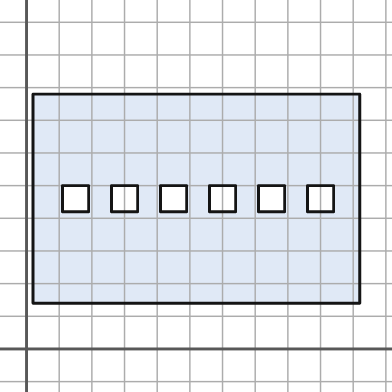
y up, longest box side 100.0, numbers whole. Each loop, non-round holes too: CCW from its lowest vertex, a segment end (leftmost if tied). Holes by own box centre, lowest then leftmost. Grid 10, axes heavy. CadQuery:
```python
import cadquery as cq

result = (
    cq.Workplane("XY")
    .moveTo(2.0, 14.0)
    .lineTo(102.0, 14.0)
    .lineTo(102.0, 78.0)
    .lineTo(2.0, 78.0)
    .close()
    .moveTo(11.0, 42.0)
    .lineTo(19.0, 42.0)
    .lineTo(19.0, 50.0)
    .lineTo(11.0, 50.0)
    .close()
    .moveTo(26.0, 42.0)
    .lineTo(34.0, 42.0)
    .lineTo(34.0, 50.0)
    .lineTo(26.0, 50.0)
    .close()
    .moveTo(41.0, 42.0)
    .lineTo(49.0, 42.0)
    .lineTo(49.0, 50.0)
    .lineTo(41.0, 50.0)
    .close()
    .moveTo(56.0, 42.0)
    .lineTo(64.0, 42.0)
    .lineTo(64.0, 50.0)
    .lineTo(56.0, 50.0)
    .close()
    .moveTo(71.0, 42.0)
    .lineTo(79.0, 42.0)
    .lineTo(79.0, 50.0)
    .lineTo(71.0, 50.0)
    .close()
    .moveTo(86.0, 42.0)
    .lineTo(94.0, 42.0)
    .lineTo(94.0, 50.0)
    .lineTo(86.0, 50.0)
    .close()
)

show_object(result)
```